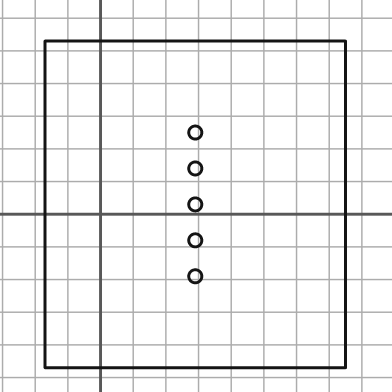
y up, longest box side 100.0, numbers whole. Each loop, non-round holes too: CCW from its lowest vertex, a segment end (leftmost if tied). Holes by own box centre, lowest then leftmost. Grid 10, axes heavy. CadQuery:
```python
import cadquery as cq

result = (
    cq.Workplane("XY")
    .moveTo(-17.0, -47.0)
    .lineTo(75.0, -47.0)
    .lineTo(75.0, 53.0)
    .lineTo(-17.0, 53.0)
    .close()
    .moveTo(29.0, -19.0)
    .circle(2.0)
    .moveTo(29.0, -8.0)
    .circle(2.0)
    .moveTo(29.0, 3.0)
    .circle(2.0)
    .moveTo(29.0, 14.0)
    .circle(2.0)
    .moveTo(29.0, 25.0)
    .circle(2.0)
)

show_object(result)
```